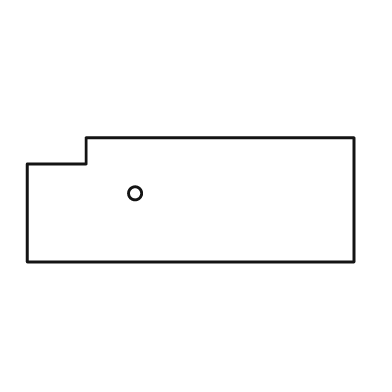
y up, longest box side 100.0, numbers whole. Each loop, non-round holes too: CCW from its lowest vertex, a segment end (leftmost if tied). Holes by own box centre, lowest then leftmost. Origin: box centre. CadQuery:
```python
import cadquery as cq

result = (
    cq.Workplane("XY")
    .moveTo(-50.0, -19.0)
    .lineTo(50.0, -19.0)
    .lineTo(50.0, 19.0)
    .lineTo(-32.0, 19.0)
    .lineTo(-32.0, 11.0)
    .lineTo(-50.0, 11.0)
    .close()
    .moveTo(-17.0, 2.0)
    .circle(2.0)
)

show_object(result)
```